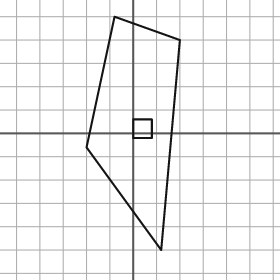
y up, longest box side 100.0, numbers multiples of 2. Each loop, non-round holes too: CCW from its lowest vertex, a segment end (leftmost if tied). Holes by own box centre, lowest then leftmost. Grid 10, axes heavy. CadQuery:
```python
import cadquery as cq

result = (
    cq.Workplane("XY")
    .moveTo(12.0, -50.0)
    .lineTo(20.0, 40.0)
    .lineTo(-8.0, 50.0)
    .lineTo(-20.0, -6.0)
    .close()
    .moveTo(0.0, -2.0)
    .lineTo(8.0, -2.0)
    .lineTo(8.0, 6.0)
    .lineTo(0.0, 6.0)
    .close()
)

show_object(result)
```